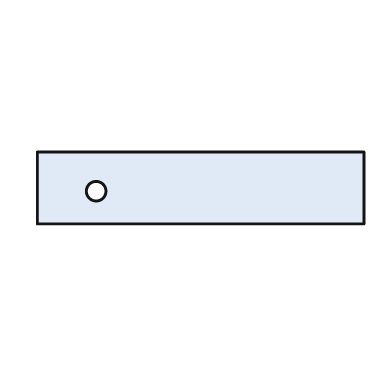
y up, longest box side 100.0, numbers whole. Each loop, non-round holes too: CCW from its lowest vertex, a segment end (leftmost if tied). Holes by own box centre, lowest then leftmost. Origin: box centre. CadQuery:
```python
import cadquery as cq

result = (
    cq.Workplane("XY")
    .moveTo(-50.0, -11.0)
    .lineTo(50.0, -11.0)
    .lineTo(50.0, 11.0)
    .lineTo(-50.0, 11.0)
    .close()
    .moveTo(-32.0, -1.0)
    .circle(3.0)
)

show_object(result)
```